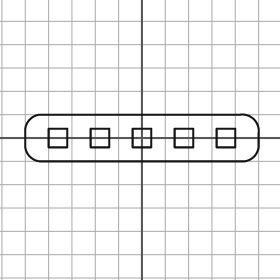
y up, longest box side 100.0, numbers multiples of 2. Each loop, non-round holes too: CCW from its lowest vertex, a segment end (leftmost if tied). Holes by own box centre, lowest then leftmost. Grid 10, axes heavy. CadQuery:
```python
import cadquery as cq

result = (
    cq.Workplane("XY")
    .moveTo(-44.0, -10.0)
    .lineTo(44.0, -10.0)
    .threePointArc((48.0, -8.0), (50.0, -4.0))
    .lineTo(50.0, 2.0)
    .threePointArc((48.0, 8.0), (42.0, 10.0))
    .lineTo(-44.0, 10.0)
    .threePointArc((-48.0, 8.0), (-50.0, 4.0))
    .lineTo(-50.0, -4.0)
    .threePointArc((-48.0, -8.0), (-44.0, -10.0))
    .close()
    .moveTo(-40.0, -4.0)
    .lineTo(-32.0, -4.0)
    .lineTo(-32.0, 4.0)
    .lineTo(-40.0, 4.0)
    .close()
    .moveTo(-22.0, -4.0)
    .lineTo(-14.0, -4.0)
    .lineTo(-14.0, 4.0)
    .lineTo(-22.0, 4.0)
    .close()
    .moveTo(-4.0, -4.0)
    .lineTo(4.0, -4.0)
    .lineTo(4.0, 4.0)
    .lineTo(-4.0, 4.0)
    .close()
    .moveTo(14.0, -4.0)
    .lineTo(22.0, -4.0)
    .lineTo(22.0, 4.0)
    .lineTo(14.0, 4.0)
    .close()
    .moveTo(32.0, -4.0)
    .lineTo(40.0, -4.0)
    .lineTo(40.0, 4.0)
    .lineTo(32.0, 4.0)
    .close()
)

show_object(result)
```